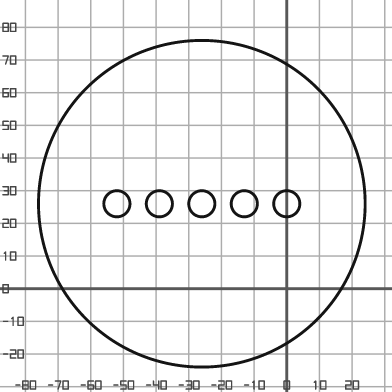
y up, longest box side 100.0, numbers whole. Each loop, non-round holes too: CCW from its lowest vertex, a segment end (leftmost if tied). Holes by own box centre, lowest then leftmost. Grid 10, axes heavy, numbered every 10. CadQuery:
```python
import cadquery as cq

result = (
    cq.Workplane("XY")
    .moveTo(-26.0, 26.0)
    .circle(50.0)
    .moveTo(-52.0, 26.0)
    .circle(4.0)
    .moveTo(-39.0, 26.0)
    .circle(4.0)
    .moveTo(-26.0, 26.0)
    .circle(4.0)
    .moveTo(-13.0, 26.0)
    .circle(4.0)
    .moveTo(0.0, 26.0)
    .circle(4.0)
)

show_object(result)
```